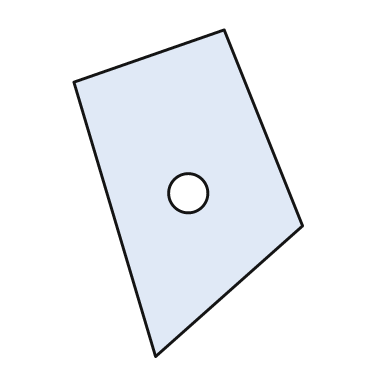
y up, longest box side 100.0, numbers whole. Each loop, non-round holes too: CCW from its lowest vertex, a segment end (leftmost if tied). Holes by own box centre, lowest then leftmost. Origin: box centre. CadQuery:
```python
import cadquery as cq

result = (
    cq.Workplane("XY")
    .moveTo(-10.0, -50.0)
    .lineTo(35.0, -10.0)
    .lineTo(11.0, 50.0)
    .lineTo(-35.0, 34.0)
    .close()
    .moveTo(0.0, 0.0)
    .circle(6.0)
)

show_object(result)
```